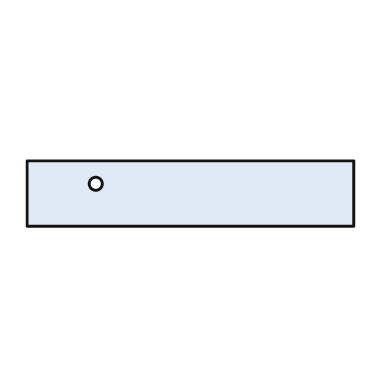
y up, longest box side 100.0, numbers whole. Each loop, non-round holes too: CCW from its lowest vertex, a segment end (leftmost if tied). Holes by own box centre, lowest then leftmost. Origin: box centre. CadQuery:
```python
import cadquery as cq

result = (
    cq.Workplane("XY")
    .moveTo(-50.0, -10.0)
    .lineTo(50.0, -10.0)
    .lineTo(50.0, 10.0)
    .lineTo(-50.0, 10.0)
    .close()
    .moveTo(-29.0, 3.0)
    .circle(2.0)
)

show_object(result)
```